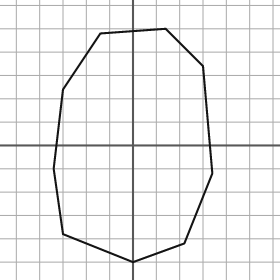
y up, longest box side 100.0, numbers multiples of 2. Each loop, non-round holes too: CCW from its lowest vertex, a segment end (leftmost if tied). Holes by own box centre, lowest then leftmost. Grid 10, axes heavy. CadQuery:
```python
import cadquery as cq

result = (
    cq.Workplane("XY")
    .moveTo(0.0, -50.0)
    .lineTo(22.0, -42.0)
    .lineTo(34.0, -12.0)
    .lineTo(30.0, 34.0)
    .lineTo(14.0, 50.0)
    .lineTo(-14.0, 48.0)
    .lineTo(-30.0, 24.0)
    .lineTo(-34.0, -10.0)
    .lineTo(-30.0, -38.0)
    .close()
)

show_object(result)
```